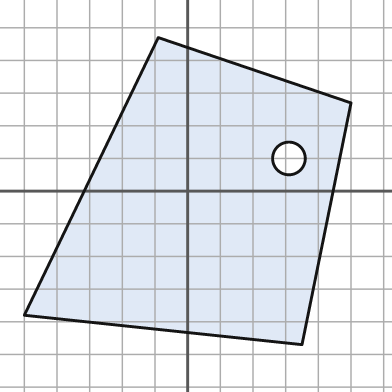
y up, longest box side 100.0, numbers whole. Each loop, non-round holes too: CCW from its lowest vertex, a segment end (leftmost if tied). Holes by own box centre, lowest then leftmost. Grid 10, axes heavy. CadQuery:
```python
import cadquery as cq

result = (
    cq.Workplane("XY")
    .moveTo(35.0, -47.0)
    .lineTo(50.0, 27.0)
    .lineTo(-9.0, 47.0)
    .lineTo(-50.0, -38.0)
    .close()
    .moveTo(31.0, 10.0)
    .circle(5.0)
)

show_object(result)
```